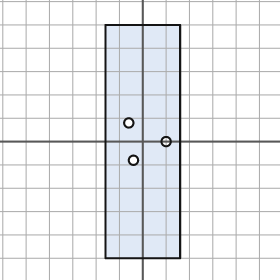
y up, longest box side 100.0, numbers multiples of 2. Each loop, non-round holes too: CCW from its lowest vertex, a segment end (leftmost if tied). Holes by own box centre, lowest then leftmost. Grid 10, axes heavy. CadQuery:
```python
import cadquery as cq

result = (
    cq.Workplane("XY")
    .moveTo(-16.0, -50.0)
    .lineTo(16.0, -50.0)
    .lineTo(16.0, 50.0)
    .lineTo(-16.0, 50.0)
    .close()
    .moveTo(-4.0, -8.0)
    .circle(2.0)
    .moveTo(10.0, 0.0)
    .circle(2.0)
    .moveTo(-6.0, 8.0)
    .circle(2.0)
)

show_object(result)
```